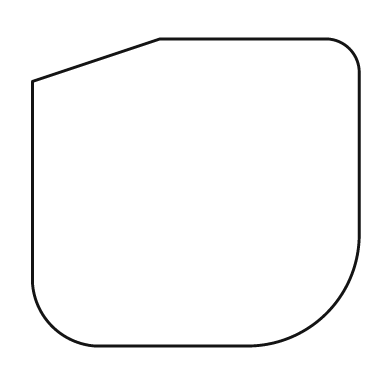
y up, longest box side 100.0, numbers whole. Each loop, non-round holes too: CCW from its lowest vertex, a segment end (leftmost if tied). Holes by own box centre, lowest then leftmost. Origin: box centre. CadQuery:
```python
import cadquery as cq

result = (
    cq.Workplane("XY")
    .moveTo(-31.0, -47.0)
    .lineTo(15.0, -47.0)
    .threePointArc((40.0, -37.0), (50.0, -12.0))
    .lineTo(50.0, 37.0)
    .threePointArc((47.0, 44.0), (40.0, 47.0))
    .lineTo(-11.0, 47.0)
    .lineTo(-50.0, 34.0)
    .lineTo(-50.0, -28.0)
    .threePointArc((-44.0, -41.0), (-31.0, -47.0))
    .close()
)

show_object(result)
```